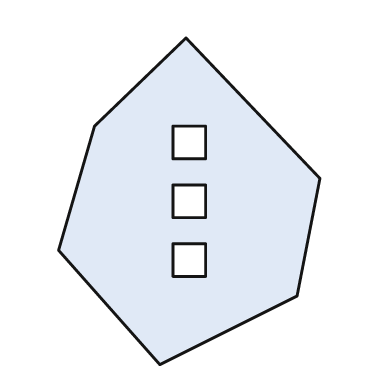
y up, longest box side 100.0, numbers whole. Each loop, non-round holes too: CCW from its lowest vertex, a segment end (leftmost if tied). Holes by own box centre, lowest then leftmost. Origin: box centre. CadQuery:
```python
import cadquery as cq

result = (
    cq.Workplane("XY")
    .moveTo(-9.0, -50.0)
    .lineTo(33.0, -29.0)
    .lineTo(40.0, 7.0)
    .lineTo(-1.0, 50.0)
    .lineTo(-29.0, 23.0)
    .lineTo(-40.0, -15.0)
    .close()
    .moveTo(-5.0, -23.0)
    .lineTo(5.0, -23.0)
    .lineTo(5.0, -13.0)
    .lineTo(-5.0, -13.0)
    .close()
    .moveTo(-5.0, -5.0)
    .lineTo(5.0, -5.0)
    .lineTo(5.0, 5.0)
    .lineTo(-5.0, 5.0)
    .close()
    .moveTo(-5.0, 13.0)
    .lineTo(5.0, 13.0)
    .lineTo(5.0, 23.0)
    .lineTo(-5.0, 23.0)
    .close()
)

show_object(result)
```